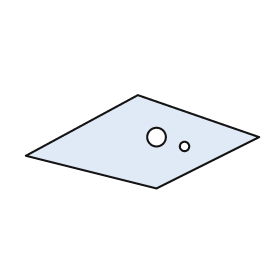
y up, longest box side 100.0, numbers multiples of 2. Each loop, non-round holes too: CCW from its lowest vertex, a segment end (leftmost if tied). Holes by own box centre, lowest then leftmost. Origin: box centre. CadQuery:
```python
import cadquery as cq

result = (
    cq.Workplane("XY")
    .moveTo(6.0, -20.0)
    .lineTo(50.0, 2.0)
    .lineTo(-2.0, 20.0)
    .lineTo(-50.0, -6.0)
    .close()
    .moveTo(18.0, -2.0)
    .circle(2.0)
    .moveTo(6.0, 2.0)
    .circle(4.0)
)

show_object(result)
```